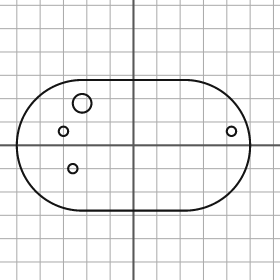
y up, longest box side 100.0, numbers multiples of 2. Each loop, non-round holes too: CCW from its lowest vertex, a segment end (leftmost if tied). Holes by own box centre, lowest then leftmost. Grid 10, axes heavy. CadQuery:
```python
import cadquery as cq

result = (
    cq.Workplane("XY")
    .moveTo(-22.0, -28.0)
    .lineTo(22.0, -28.0)
    .threePointArc((50.0, 0.0), (22.0, 28.0))
    .lineTo(-22.0, 28.0)
    .threePointArc((-50.0, 0.0), (-22.0, -28.0))
    .close()
    .moveTo(-26.0, -10.0)
    .circle(2.0)
    .moveTo(-30.0, 6.0)
    .circle(2.0)
    .moveTo(42.0, 6.0)
    .circle(2.0)
    .moveTo(-22.0, 18.0)
    .circle(4.0)
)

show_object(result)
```